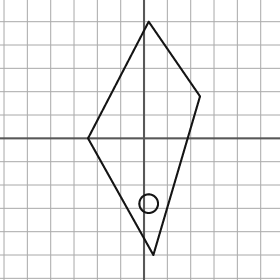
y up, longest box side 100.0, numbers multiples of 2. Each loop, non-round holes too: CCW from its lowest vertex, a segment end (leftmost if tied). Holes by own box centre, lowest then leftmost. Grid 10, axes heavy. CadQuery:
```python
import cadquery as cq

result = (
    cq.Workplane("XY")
    .moveTo(4.0, -50.0)
    .lineTo(24.0, 18.0)
    .lineTo(2.0, 50.0)
    .lineTo(-24.0, 0.0)
    .close()
    .moveTo(2.0, -28.0)
    .circle(4.0)
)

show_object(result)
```